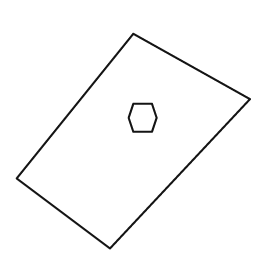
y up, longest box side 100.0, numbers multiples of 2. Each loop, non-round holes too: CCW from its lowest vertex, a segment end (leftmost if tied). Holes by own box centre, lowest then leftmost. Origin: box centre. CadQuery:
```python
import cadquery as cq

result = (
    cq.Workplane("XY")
    .moveTo(-10.0, -46.0)
    .lineTo(50.0, 18.0)
    .lineTo(0.0, 46.0)
    .lineTo(-50.0, -16.0)
    .close()
    .moveTo(0.0, 4.0)
    .lineTo(8.0, 4.0)
    .lineTo(10.0, 10.0)
    .lineTo(8.0, 16.0)
    .lineTo(0.0, 16.0)
    .lineTo(-2.0, 10.0)
    .close()
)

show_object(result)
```